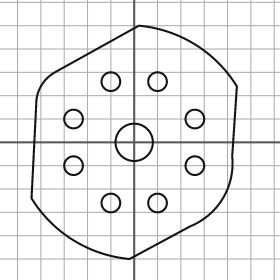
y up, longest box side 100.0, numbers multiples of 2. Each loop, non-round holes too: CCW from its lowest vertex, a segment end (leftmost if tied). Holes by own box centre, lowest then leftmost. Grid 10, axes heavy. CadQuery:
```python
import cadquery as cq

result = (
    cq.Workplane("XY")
    .moveTo(-2.0, -50.0)
    .lineTo(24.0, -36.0)
    .threePointArc((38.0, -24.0), (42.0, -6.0))
    .lineTo(44.0, 24.0)
    .threePointArc((26.0, 42.0), (2.0, 50.0))
    .lineTo(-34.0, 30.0)
    .threePointArc((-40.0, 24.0), (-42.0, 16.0))
    .lineTo(-44.0, -24.0)
    .threePointArc((-26.0, -42.0), (-2.0, -50.0))
    .close()
    .moveTo(-10.0, -26.0)
    .circle(4.0)
    .moveTo(10.0, -26.0)
    .circle(4.0)
    .moveTo(-26.0, -10.0)
    .circle(4.0)
    .moveTo(26.0, -10.0)
    .circle(4.0)
    .moveTo(0.0, 0.0)
    .circle(8.0)
    .moveTo(-26.0, 10.0)
    .circle(4.0)
    .moveTo(26.0, 10.0)
    .circle(4.0)
    .moveTo(-10.0, 26.0)
    .circle(4.0)
    .moveTo(10.0, 26.0)
    .circle(4.0)
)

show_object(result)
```